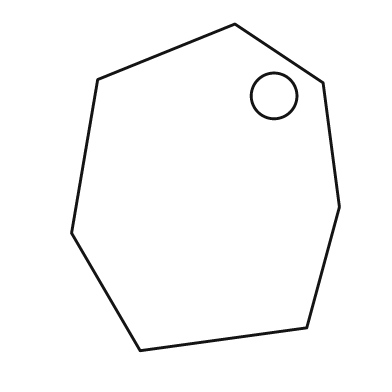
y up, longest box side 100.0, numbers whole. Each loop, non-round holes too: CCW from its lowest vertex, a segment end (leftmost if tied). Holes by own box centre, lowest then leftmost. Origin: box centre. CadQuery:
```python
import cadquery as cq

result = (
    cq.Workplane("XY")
    .moveTo(-20.0, -50.0)
    .lineTo(31.0, -43.0)
    .lineTo(41.0, -6.0)
    .lineTo(36.0, 32.0)
    .lineTo(9.0, 50.0)
    .lineTo(-33.0, 33.0)
    .lineTo(-41.0, -14.0)
    .close()
    .moveTo(21.0, 28.0)
    .circle(7.0)
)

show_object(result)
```